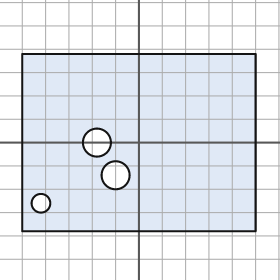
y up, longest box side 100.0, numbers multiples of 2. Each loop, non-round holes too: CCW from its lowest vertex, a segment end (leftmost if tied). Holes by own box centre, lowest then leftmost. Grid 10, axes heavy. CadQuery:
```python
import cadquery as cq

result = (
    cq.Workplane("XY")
    .moveTo(-50.0, -38.0)
    .lineTo(50.0, -38.0)
    .lineTo(50.0, 38.0)
    .lineTo(-50.0, 38.0)
    .close()
    .moveTo(-42.0, -26.0)
    .circle(4.0)
    .moveTo(-10.0, -14.0)
    .circle(6.0)
    .moveTo(-18.0, 0.0)
    .circle(6.0)
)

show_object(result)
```